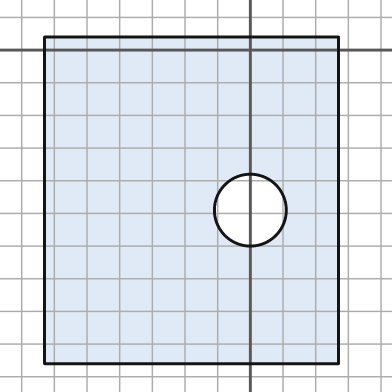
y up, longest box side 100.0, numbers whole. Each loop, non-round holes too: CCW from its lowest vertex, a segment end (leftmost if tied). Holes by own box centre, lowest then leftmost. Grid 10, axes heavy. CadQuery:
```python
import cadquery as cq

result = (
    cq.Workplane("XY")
    .moveTo(-63.0, -96.0)
    .lineTo(27.0, -96.0)
    .lineTo(27.0, 4.0)
    .lineTo(-63.0, 4.0)
    .close()
    .moveTo(0.0, -49.0)
    .circle(11.0)
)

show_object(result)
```